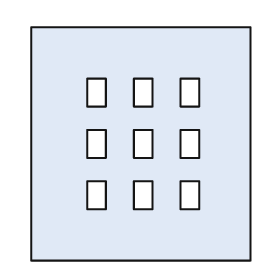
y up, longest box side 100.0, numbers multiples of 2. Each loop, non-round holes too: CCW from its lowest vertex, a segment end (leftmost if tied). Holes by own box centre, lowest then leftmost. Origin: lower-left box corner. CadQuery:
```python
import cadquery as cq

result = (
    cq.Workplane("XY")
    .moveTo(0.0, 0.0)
    .lineTo(94.0, 0.0)
    .lineTo(94.0, 100.0)
    .lineTo(0.0, 100.0)
    .close()
    .moveTo(24.0, 22.0)
    .lineTo(32.0, 22.0)
    .lineTo(32.0, 34.0)
    .lineTo(24.0, 34.0)
    .close()
    .moveTo(44.0, 22.0)
    .lineTo(52.0, 22.0)
    .lineTo(52.0, 34.0)
    .lineTo(44.0, 34.0)
    .close()
    .moveTo(64.0, 22.0)
    .lineTo(72.0, 22.0)
    .lineTo(72.0, 34.0)
    .lineTo(64.0, 34.0)
    .close()
    .moveTo(24.0, 44.0)
    .lineTo(32.0, 44.0)
    .lineTo(32.0, 56.0)
    .lineTo(24.0, 56.0)
    .close()
    .moveTo(44.0, 44.0)
    .lineTo(52.0, 44.0)
    .lineTo(52.0, 56.0)
    .lineTo(44.0, 56.0)
    .close()
    .moveTo(64.0, 44.0)
    .lineTo(72.0, 44.0)
    .lineTo(72.0, 56.0)
    .lineTo(64.0, 56.0)
    .close()
    .moveTo(24.0, 66.0)
    .lineTo(32.0, 66.0)
    .lineTo(32.0, 78.0)
    .lineTo(24.0, 78.0)
    .close()
    .moveTo(44.0, 66.0)
    .lineTo(52.0, 66.0)
    .lineTo(52.0, 78.0)
    .lineTo(44.0, 78.0)
    .close()
    .moveTo(64.0, 66.0)
    .lineTo(72.0, 66.0)
    .lineTo(72.0, 78.0)
    .lineTo(64.0, 78.0)
    .close()
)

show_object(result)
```